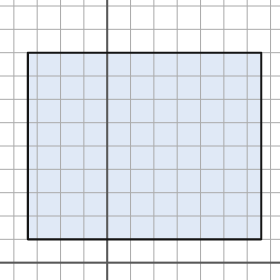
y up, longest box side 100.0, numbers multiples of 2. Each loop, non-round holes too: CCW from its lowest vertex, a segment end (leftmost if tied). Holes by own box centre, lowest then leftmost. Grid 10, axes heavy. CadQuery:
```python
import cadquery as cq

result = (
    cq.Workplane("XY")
    .moveTo(-34.0, 10.0)
    .lineTo(66.0, 10.0)
    .lineTo(66.0, 90.0)
    .lineTo(-34.0, 90.0)
    .close()
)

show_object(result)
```